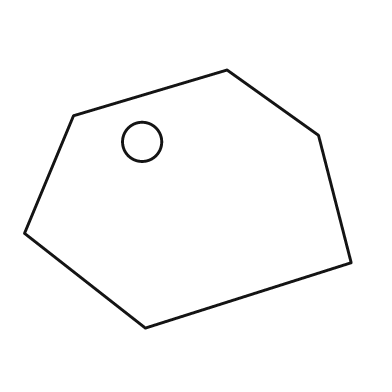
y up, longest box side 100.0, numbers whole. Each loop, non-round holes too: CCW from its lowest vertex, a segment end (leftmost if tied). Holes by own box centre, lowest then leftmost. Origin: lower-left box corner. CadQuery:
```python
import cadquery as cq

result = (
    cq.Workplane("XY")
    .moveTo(37.0, 0.0)
    .lineTo(100.0, 20.0)
    .lineTo(90.0, 59.0)
    .lineTo(62.0, 79.0)
    .lineTo(15.0, 65.0)
    .lineTo(0.0, 29.0)
    .close()
    .moveTo(36.0, 57.0)
    .circle(6.0)
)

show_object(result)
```